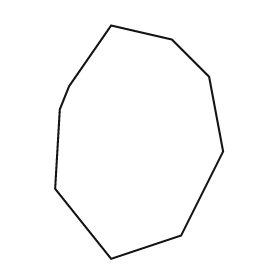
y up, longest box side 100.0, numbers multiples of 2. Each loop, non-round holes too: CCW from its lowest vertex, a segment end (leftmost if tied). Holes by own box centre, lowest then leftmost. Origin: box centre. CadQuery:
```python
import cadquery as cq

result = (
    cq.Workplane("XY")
    .moveTo(-12.0, -50.0)
    .lineTo(18.0, -40.0)
    .lineTo(36.0, -4.0)
    .lineTo(30.0, 28.0)
    .lineTo(14.0, 44.0)
    .lineTo(-12.0, 50.0)
    .lineTo(-30.0, 24.0)
    .lineTo(-34.0, 14.0)
    .lineTo(-36.0, -20.0)
    .close()
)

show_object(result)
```